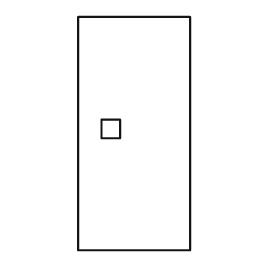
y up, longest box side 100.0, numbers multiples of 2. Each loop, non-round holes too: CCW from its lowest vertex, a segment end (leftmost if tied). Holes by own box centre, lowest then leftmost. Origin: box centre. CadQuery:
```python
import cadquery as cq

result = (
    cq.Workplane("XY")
    .moveTo(-24.0, -50.0)
    .lineTo(24.0, -50.0)
    .lineTo(24.0, 50.0)
    .lineTo(-24.0, 50.0)
    .close()
    .moveTo(-14.0, -2.0)
    .lineTo(-6.0, -2.0)
    .lineTo(-6.0, 6.0)
    .lineTo(-14.0, 6.0)
    .close()
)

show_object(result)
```